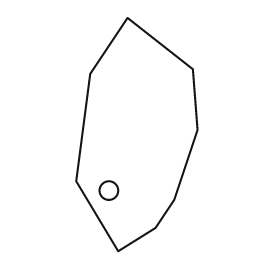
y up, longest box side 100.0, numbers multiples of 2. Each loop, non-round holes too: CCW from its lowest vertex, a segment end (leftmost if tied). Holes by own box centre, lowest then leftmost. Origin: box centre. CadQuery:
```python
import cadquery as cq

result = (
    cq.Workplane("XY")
    .moveTo(-8.0, -50.0)
    .lineTo(8.0, -40.0)
    .lineTo(16.0, -28.0)
    .lineTo(26.0, 2.0)
    .lineTo(24.0, 28.0)
    .lineTo(-4.0, 50.0)
    .lineTo(-20.0, 26.0)
    .lineTo(-26.0, -20.0)
    .close()
    .moveTo(-12.0, -24.0)
    .circle(4.0)
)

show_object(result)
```